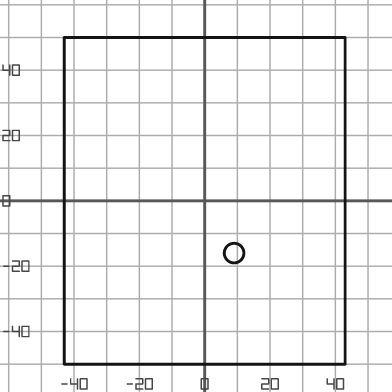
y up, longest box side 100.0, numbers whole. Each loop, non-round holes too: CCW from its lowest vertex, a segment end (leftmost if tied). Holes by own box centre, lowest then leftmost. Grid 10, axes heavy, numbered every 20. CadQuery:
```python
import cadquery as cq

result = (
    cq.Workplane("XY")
    .moveTo(-43.0, -50.0)
    .lineTo(43.0, -50.0)
    .lineTo(43.0, 50.0)
    .lineTo(-43.0, 50.0)
    .close()
    .moveTo(9.0, -16.0)
    .circle(3.0)
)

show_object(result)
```